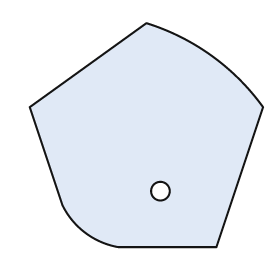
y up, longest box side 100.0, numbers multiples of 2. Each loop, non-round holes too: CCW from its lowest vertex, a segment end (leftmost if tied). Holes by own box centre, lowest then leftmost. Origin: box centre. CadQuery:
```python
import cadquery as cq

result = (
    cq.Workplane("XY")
    .moveTo(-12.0, -48.0)
    .lineTo(30.0, -48.0)
    .lineTo(50.0, 12.0)
    .threePointArc((28.0, 34.0), (0.0, 48.0))
    .lineTo(-50.0, 12.0)
    .lineTo(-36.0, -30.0)
    .threePointArc((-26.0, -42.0), (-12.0, -48.0))
    .close()
    .moveTo(6.0, -24.0)
    .circle(4.0)
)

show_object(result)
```